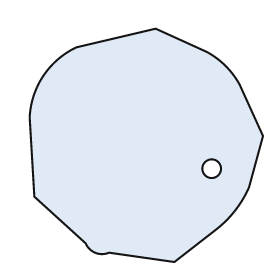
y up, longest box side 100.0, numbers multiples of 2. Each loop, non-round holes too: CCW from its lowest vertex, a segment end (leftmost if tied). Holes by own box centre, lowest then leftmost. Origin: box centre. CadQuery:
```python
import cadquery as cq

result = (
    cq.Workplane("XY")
    .moveTo(12.0, -50.0)
    .lineTo(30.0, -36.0)
    .threePointArc((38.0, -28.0), (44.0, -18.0))
    .lineTo(50.0, 4.0)
    .lineTo(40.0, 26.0)
    .threePointArc((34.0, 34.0), (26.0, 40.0))
    .lineTo(4.0, 50.0)
    .lineTo(-30.0, 42.0)
    .threePointArc((-44.0, 30.0), (-50.0, 12.0))
    .lineTo(-48.0, -22.0)
    .lineTo(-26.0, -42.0)
    .threePointArc((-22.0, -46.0), (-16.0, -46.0))
    .close()
    .moveTo(28.0, -10.0)
    .circle(4.0)
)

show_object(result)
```